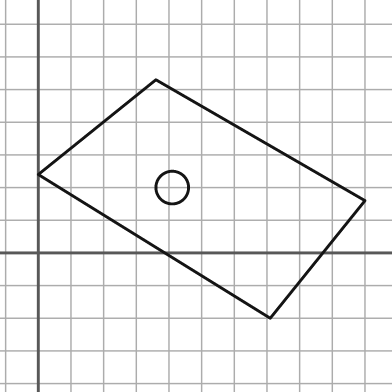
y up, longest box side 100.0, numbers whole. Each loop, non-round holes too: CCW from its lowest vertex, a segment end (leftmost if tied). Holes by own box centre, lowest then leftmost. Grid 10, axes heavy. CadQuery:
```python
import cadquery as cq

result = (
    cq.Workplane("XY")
    .moveTo(71.0, -20.0)
    .lineTo(100.0, 16.0)
    .lineTo(36.0, 53.0)
    .lineTo(0.0, 24.0)
    .close()
    .moveTo(41.0, 20.0)
    .circle(5.0)
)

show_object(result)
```